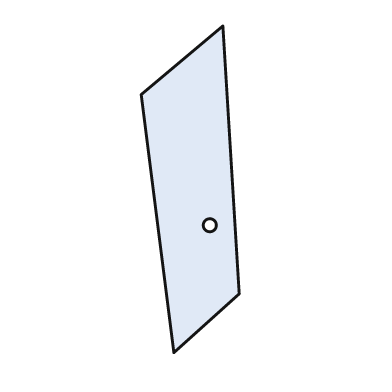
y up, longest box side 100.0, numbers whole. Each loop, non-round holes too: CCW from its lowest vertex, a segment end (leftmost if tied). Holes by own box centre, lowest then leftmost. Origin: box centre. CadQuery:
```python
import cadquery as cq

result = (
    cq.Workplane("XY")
    .moveTo(-5.0, -50.0)
    .lineTo(15.0, -32.0)
    .lineTo(10.0, 50.0)
    .lineTo(-15.0, 29.0)
    .close()
    .moveTo(6.0, -11.0)
    .circle(2.0)
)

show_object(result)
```